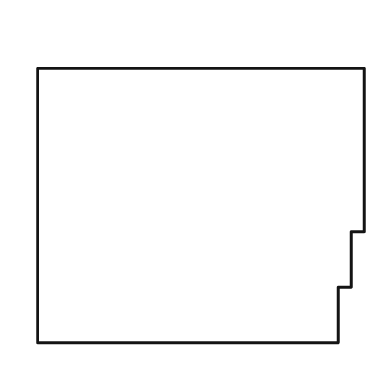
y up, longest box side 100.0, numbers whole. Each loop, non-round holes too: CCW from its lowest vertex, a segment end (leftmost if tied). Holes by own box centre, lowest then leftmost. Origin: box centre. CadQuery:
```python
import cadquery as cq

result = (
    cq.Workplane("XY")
    .moveTo(-50.0, -42.0)
    .lineTo(42.0, -42.0)
    .lineTo(42.0, -25.0)
    .lineTo(46.0, -25.0)
    .lineTo(46.0, -8.0)
    .lineTo(50.0, -8.0)
    .lineTo(50.0, 42.0)
    .lineTo(-50.0, 42.0)
    .close()
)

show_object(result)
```